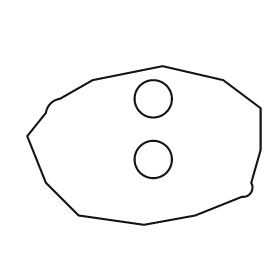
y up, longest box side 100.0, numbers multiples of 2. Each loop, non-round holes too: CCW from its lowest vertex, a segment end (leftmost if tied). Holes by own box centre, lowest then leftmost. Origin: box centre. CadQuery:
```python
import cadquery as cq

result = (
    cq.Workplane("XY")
    .moveTo(0.0, -34.0)
    .lineTo(22.0, -30.0)
    .lineTo(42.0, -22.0)
    .threePointArc((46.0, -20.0), (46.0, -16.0))
    .lineTo(50.0, -2.0)
    .lineTo(50.0, 16.0)
    .lineTo(34.0, 28.0)
    .lineTo(8.0, 34.0)
    .lineTo(-22.0, 28.0)
    .lineTo(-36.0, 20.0)
    .threePointArc((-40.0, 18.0), (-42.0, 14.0))
    .lineTo(-50.0, 4.0)
    .lineTo(-42.0, -16.0)
    .lineTo(-28.0, -30.0)
    .close()
    .moveTo(4.0, -6.0)
    .circle(8.0)
    .moveTo(4.0, 20.0)
    .circle(8.0)
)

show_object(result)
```